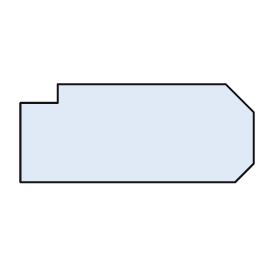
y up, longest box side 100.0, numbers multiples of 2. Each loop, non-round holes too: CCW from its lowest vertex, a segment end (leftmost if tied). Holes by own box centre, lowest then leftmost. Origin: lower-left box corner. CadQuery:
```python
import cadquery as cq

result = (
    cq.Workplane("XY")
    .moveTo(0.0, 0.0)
    .lineTo(92.0, 0.0)
    .lineTo(100.0, 8.0)
    .lineTo(100.0, 30.0)
    .lineTo(88.0, 42.0)
    .lineTo(16.0, 42.0)
    .lineTo(16.0, 34.0)
    .lineTo(0.0, 34.0)
    .close()
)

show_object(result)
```